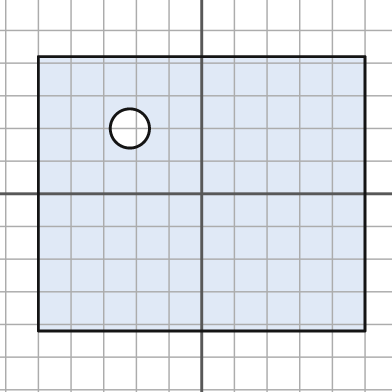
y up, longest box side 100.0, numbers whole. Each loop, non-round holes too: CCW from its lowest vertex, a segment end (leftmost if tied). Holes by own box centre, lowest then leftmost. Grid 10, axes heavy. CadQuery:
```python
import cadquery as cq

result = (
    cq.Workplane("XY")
    .moveTo(-50.0, -42.0)
    .lineTo(50.0, -42.0)
    .lineTo(50.0, 42.0)
    .lineTo(-50.0, 42.0)
    .close()
    .moveTo(-22.0, 20.0)
    .circle(6.0)
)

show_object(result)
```